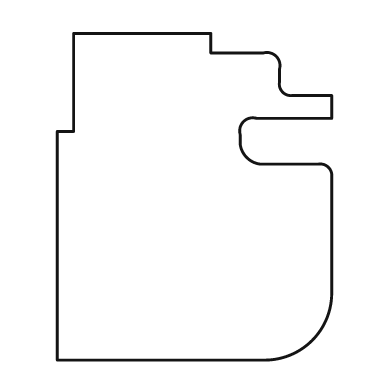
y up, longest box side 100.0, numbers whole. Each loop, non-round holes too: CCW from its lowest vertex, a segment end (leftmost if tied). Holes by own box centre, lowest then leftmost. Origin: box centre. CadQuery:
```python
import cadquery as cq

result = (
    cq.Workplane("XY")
    .moveTo(-42.0, -50.0)
    .lineTo(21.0, -50.0)
    .threePointArc((36.0, -44.0), (42.0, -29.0))
    .lineTo(42.0, 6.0)
    .threePointArc((41.0, 9.0), (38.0, 10.0))
    .lineTo(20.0, 10.0)
    .threePointArc((16.0, 12.0), (14.0, 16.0))
    .lineTo(14.0, 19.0)
    .threePointArc((15.0, 23.0), (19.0, 24.0))
    .lineTo(42.0, 24.0)
    .lineTo(42.0, 31.0)
    .lineTo(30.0, 31.0)
    .threePointArc((27.0, 32.0), (26.0, 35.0))
    .lineTo(26.0, 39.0)
    .threePointArc((25.0, 43.0), (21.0, 44.0))
    .lineTo(5.0, 44.0)
    .lineTo(5.0, 50.0)
    .lineTo(-37.0, 50.0)
    .lineTo(-37.0, 20.0)
    .lineTo(-42.0, 20.0)
    .close()
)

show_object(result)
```